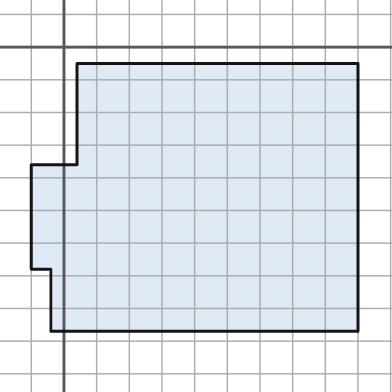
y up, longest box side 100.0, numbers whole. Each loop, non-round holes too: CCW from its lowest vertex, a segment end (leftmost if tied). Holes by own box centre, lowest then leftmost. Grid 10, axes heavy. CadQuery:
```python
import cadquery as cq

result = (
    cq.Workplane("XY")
    .moveTo(-4.0, -87.0)
    .lineTo(90.0, -87.0)
    .lineTo(90.0, -5.0)
    .lineTo(4.0, -5.0)
    .lineTo(4.0, -36.0)
    .lineTo(-10.0, -36.0)
    .lineTo(-10.0, -68.0)
    .lineTo(-4.0, -68.0)
    .close()
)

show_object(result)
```